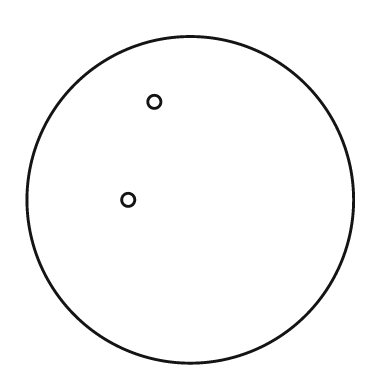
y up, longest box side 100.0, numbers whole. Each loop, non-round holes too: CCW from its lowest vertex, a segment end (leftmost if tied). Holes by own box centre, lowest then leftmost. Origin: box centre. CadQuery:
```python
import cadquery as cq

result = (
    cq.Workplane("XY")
    .moveTo(0.0, 0.0)
    .circle(50.0)
    .moveTo(-19.0, 0.0)
    .circle(2.0)
    .moveTo(-11.0, 30.0)
    .circle(2.0)
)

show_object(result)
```